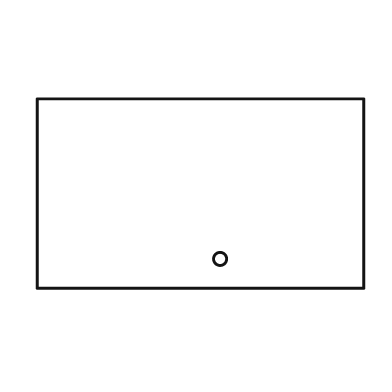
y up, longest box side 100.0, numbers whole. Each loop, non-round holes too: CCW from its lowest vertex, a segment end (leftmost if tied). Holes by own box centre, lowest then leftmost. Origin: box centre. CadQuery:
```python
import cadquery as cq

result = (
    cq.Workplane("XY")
    .moveTo(-50.0, -29.0)
    .lineTo(50.0, -29.0)
    .lineTo(50.0, 29.0)
    .lineTo(-50.0, 29.0)
    .close()
    .moveTo(6.0, -20.0)
    .circle(2.0)
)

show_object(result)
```